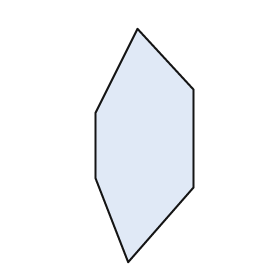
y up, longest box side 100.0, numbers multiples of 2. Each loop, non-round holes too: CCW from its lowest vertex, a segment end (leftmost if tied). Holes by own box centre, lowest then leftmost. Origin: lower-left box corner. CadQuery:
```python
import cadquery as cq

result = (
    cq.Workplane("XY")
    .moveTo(14.0, 0.0)
    .lineTo(42.0, 32.0)
    .lineTo(42.0, 74.0)
    .lineTo(18.0, 100.0)
    .lineTo(0.0, 64.0)
    .lineTo(0.0, 36.0)
    .close()
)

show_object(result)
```